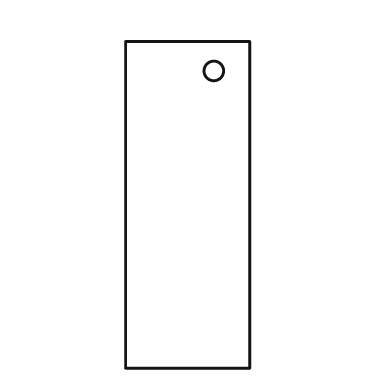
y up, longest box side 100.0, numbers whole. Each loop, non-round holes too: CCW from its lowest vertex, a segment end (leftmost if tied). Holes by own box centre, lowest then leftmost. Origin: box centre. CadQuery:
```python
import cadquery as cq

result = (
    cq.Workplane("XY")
    .moveTo(-19.0, -50.0)
    .lineTo(19.0, -50.0)
    .lineTo(19.0, 50.0)
    .lineTo(-19.0, 50.0)
    .close()
    .moveTo(8.0, 41.0)
    .circle(3.0)
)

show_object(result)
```